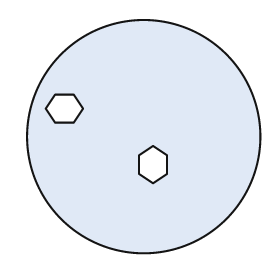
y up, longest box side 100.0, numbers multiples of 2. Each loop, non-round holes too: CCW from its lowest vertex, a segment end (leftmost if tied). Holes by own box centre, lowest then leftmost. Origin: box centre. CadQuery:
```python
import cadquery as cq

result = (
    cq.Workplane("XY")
    .moveTo(0.0, 0.0)
    .circle(50.0)
    .moveTo(4.0, -20.0)
    .lineTo(10.0, -16.0)
    .lineTo(10.0, -8.0)
    .lineTo(4.0, -4.0)
    .lineTo(-2.0, -8.0)
    .lineTo(-2.0, -16.0)
    .close()
    .moveTo(-38.0, 6.0)
    .lineTo(-30.0, 6.0)
    .lineTo(-26.0, 12.0)
    .lineTo(-30.0, 18.0)
    .lineTo(-38.0, 18.0)
    .lineTo(-42.0, 12.0)
    .close()
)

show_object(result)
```